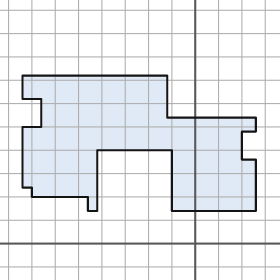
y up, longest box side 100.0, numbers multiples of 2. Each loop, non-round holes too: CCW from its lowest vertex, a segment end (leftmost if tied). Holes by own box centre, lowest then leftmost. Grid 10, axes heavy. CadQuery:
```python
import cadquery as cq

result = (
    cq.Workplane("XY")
    .moveTo(-46.0, 14.0)
    .lineTo(-42.0, 14.0)
    .lineTo(-42.0, 40.0)
    .lineTo(-10.0, 40.0)
    .lineTo(-10.0, 14.0)
    .lineTo(26.0, 14.0)
    .lineTo(26.0, 36.0)
    .lineTo(20.0, 36.0)
    .lineTo(20.0, 48.0)
    .lineTo(26.0, 48.0)
    .lineTo(26.0, 54.0)
    .lineTo(-12.0, 54.0)
    .lineTo(-12.0, 72.0)
    .lineTo(-74.0, 72.0)
    .lineTo(-74.0, 62.0)
    .lineTo(-66.0, 62.0)
    .lineTo(-66.0, 50.0)
    .lineTo(-74.0, 50.0)
    .lineTo(-74.0, 24.0)
    .lineTo(-70.0, 24.0)
    .lineTo(-70.0, 20.0)
    .lineTo(-46.0, 20.0)
    .close()
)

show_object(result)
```